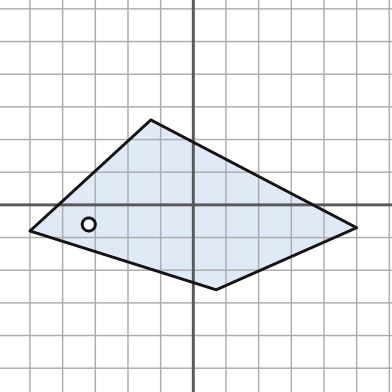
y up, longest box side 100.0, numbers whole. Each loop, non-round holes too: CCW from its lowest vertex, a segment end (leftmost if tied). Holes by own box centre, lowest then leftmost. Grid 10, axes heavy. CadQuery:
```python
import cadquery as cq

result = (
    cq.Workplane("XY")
    .moveTo(7.0, -26.0)
    .lineTo(50.0, -7.0)
    .lineTo(-13.0, 26.0)
    .lineTo(-50.0, -8.0)
    .close()
    .moveTo(-32.0, -6.0)
    .circle(2.0)
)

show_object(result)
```